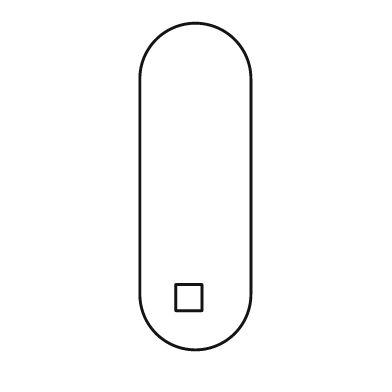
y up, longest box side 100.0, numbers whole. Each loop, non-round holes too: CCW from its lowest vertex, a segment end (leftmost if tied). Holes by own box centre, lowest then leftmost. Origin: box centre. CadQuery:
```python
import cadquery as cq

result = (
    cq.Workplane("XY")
    .moveTo(-17.0, -33.0)
    .threePointArc((0.0, -50.0), (17.0, -33.0))
    .lineTo(17.0, 33.0)
    .threePointArc((0.0, 50.0), (-17.0, 33.0))
    .close()
    .moveTo(-6.0, -38.0)
    .lineTo(2.0, -38.0)
    .lineTo(2.0, -30.0)
    .lineTo(-6.0, -30.0)
    .close()
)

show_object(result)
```